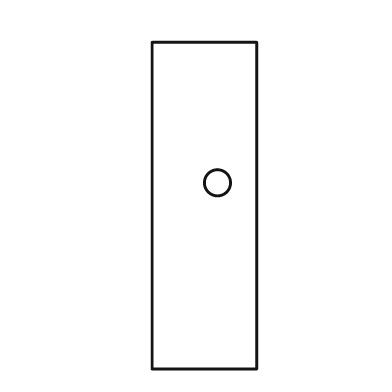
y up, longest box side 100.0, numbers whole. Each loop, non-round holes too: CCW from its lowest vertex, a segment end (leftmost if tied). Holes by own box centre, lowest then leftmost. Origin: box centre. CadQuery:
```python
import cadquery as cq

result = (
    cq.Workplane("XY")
    .moveTo(-16.0, -50.0)
    .lineTo(16.0, -50.0)
    .lineTo(16.0, 50.0)
    .lineTo(-16.0, 50.0)
    .close()
    .moveTo(4.0, 7.0)
    .circle(4.0)
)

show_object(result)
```